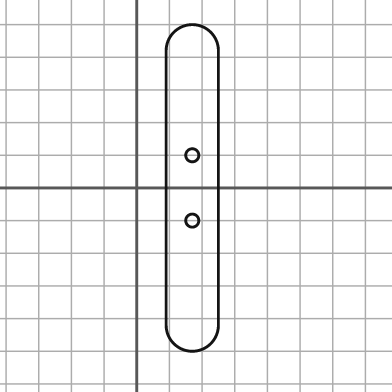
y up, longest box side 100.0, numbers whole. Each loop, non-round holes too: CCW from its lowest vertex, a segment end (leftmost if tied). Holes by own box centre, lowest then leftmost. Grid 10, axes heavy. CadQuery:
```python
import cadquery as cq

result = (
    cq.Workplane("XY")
    .moveTo(9.0, -42.0)
    .threePointArc((17.0, -50.0), (25.0, -42.0))
    .lineTo(25.0, 42.0)
    .threePointArc((17.0, 50.0), (9.0, 42.0))
    .close()
    .moveTo(17.0, -10.0)
    .circle(2.0)
    .moveTo(17.0, 10.0)
    .circle(2.0)
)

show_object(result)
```